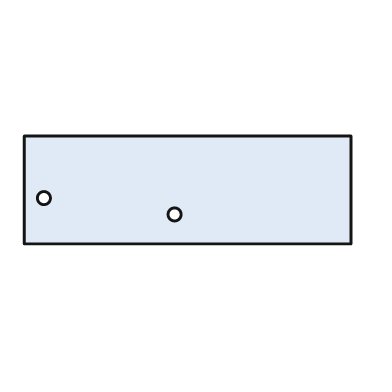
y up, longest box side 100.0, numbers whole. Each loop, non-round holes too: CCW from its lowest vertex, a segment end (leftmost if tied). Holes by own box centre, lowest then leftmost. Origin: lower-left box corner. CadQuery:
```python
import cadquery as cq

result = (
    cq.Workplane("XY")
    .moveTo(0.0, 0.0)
    .lineTo(100.0, 0.0)
    .lineTo(100.0, 33.0)
    .lineTo(0.0, 33.0)
    .close()
    .moveTo(46.0, 9.0)
    .circle(2.0)
    .moveTo(6.0, 14.0)
    .circle(2.0)
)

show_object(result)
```